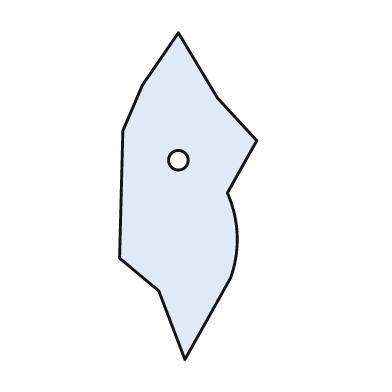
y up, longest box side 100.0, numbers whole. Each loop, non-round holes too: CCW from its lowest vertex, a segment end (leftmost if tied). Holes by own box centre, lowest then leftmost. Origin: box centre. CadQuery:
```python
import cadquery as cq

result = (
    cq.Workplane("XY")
    .moveTo(-1.0, -50.0)
    .lineTo(13.0, -25.0)
    .threePointArc((15.0, -12.0), (12.0, 1.0))
    .lineTo(21.0, 17.0)
    .lineTo(9.0, 30.0)
    .lineTo(-3.0, 50.0)
    .lineTo(-14.0, 34.0)
    .lineTo(-20.0, 20.0)
    .lineTo(-21.0, -19.0)
    .lineTo(-9.0, -29.0)
    .close()
    .moveTo(-3.0, 11.0)
    .circle(3.0)
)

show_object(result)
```